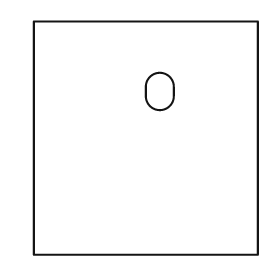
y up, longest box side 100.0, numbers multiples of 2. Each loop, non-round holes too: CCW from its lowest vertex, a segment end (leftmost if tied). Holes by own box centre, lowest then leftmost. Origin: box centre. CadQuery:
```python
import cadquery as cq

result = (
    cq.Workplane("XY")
    .moveTo(-48.0, -50.0)
    .lineTo(48.0, -50.0)
    .lineTo(48.0, 50.0)
    .lineTo(-48.0, 50.0)
    .close()
    .moveTo(0.0, 18.0)
    .threePointArc((6.0, 12.0), (12.0, 18.0))
    .lineTo(12.0, 22.0)
    .threePointArc((6.0, 28.0), (0.0, 22.0))
    .close()
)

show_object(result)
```